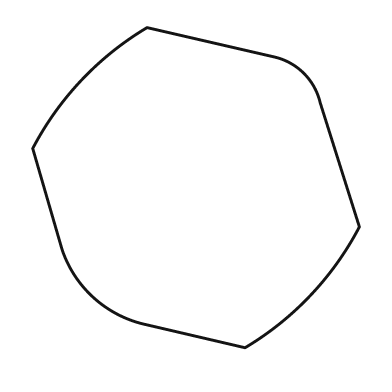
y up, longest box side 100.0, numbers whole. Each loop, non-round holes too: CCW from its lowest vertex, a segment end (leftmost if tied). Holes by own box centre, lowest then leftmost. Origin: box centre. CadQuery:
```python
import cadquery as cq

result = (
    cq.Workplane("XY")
    .moveTo(15.0, -49.0)
    .threePointArc((35.0, -33.0), (50.0, -12.0))
    .lineTo(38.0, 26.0)
    .threePointArc((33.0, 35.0), (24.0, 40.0))
    .lineTo(-15.0, 49.0)
    .threePointArc((-35.0, 33.0), (-50.0, 12.0))
    .lineTo(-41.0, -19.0)
    .threePointArc((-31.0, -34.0), (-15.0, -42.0))
    .close()
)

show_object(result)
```